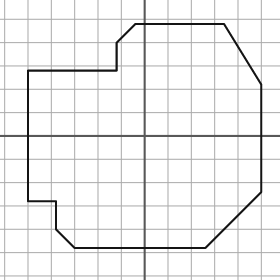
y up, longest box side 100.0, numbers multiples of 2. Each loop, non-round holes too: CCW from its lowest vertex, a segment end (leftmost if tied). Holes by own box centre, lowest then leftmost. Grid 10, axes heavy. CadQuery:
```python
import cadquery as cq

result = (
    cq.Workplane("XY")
    .moveTo(-30.0, -48.0)
    .lineTo(26.0, -48.0)
    .lineTo(50.0, -24.0)
    .lineTo(50.0, 22.0)
    .lineTo(34.0, 48.0)
    .lineTo(-4.0, 48.0)
    .lineTo(-12.0, 40.0)
    .lineTo(-12.0, 28.0)
    .lineTo(-50.0, 28.0)
    .lineTo(-50.0, -28.0)
    .lineTo(-38.0, -28.0)
    .lineTo(-38.0, -40.0)
    .close()
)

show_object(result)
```